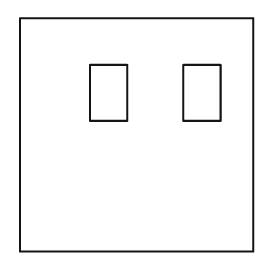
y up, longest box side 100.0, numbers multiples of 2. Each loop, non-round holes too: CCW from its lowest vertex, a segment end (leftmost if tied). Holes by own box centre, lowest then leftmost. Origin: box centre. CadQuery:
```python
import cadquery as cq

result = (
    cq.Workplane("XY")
    .moveTo(-50.0, -50.0)
    .lineTo(50.0, -50.0)
    .lineTo(50.0, 50.0)
    .lineTo(-50.0, 50.0)
    .close()
    .moveTo(-20.0, 6.0)
    .lineTo(-4.0, 6.0)
    .lineTo(-4.0, 30.0)
    .lineTo(-20.0, 30.0)
    .close()
    .moveTo(20.0, 6.0)
    .lineTo(36.0, 6.0)
    .lineTo(36.0, 30.0)
    .lineTo(20.0, 30.0)
    .close()
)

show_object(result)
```